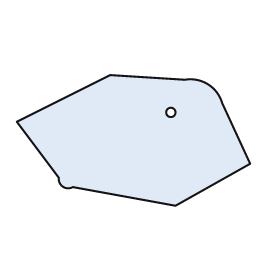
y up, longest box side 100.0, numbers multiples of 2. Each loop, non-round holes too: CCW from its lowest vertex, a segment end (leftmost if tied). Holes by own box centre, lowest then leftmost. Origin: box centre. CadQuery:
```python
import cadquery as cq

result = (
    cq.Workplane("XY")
    .moveTo(18.0, -28.0)
    .lineTo(50.0, -10.0)
    .lineTo(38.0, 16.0)
    .threePointArc((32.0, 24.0), (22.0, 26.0))
    .lineTo(-10.0, 28.0)
    .lineTo(-50.0, 8.0)
    .lineTo(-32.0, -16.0)
    .threePointArc((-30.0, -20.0), (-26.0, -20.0))
    .close()
    .moveTo(16.0, 12.0)
    .circle(2.0)
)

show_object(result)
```